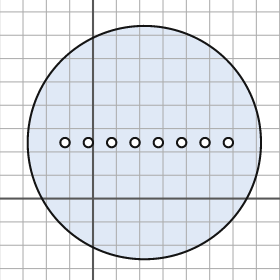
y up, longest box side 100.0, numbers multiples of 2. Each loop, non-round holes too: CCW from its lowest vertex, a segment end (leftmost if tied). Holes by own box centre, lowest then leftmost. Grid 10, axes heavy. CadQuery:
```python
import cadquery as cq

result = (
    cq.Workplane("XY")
    .moveTo(22.0, 24.0)
    .circle(50.0)
    .moveTo(-12.0, 24.0)
    .circle(2.0)
    .moveTo(-2.0, 24.0)
    .circle(2.0)
    .moveTo(8.0, 24.0)
    .circle(2.0)
    .moveTo(18.0, 24.0)
    .circle(2.0)
    .moveTo(28.0, 24.0)
    .circle(2.0)
    .moveTo(38.0, 24.0)
    .circle(2.0)
    .moveTo(48.0, 24.0)
    .circle(2.0)
    .moveTo(58.0, 24.0)
    .circle(2.0)
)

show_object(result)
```